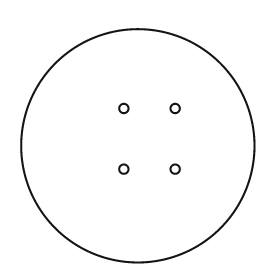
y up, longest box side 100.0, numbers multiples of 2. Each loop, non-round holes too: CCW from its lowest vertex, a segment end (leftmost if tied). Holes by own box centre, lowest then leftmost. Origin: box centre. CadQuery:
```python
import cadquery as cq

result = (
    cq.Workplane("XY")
    .moveTo(0.0, 0.0)
    .circle(50.0)
    .moveTo(-6.0, -10.0)
    .circle(2.0)
    .moveTo(16.0, -10.0)
    .circle(2.0)
    .moveTo(-6.0, 16.0)
    .circle(2.0)
    .moveTo(16.0, 16.0)
    .circle(2.0)
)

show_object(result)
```